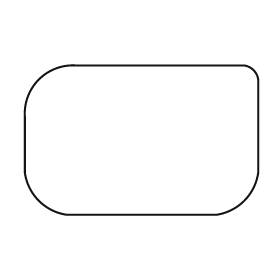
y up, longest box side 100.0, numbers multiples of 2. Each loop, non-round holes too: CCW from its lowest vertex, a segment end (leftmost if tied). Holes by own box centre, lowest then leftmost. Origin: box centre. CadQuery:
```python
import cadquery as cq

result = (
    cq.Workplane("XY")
    .moveTo(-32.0, -32.0)
    .lineTo(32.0, -32.0)
    .threePointArc((44.0, -26.0), (50.0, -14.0))
    .lineTo(50.0, 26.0)
    .threePointArc((48.0, 30.0), (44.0, 32.0))
    .lineTo(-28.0, 32.0)
    .threePointArc((-44.0, 26.0), (-50.0, 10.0))
    .lineTo(-50.0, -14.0)
    .threePointArc((-44.0, -26.0), (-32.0, -32.0))
    .close()
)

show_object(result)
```